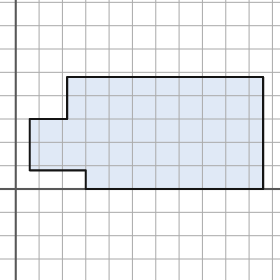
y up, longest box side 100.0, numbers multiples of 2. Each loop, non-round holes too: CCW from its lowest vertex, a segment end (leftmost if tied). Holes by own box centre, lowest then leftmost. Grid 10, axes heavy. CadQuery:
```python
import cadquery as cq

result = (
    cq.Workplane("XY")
    .moveTo(30.0, 0.0)
    .lineTo(106.0, 0.0)
    .lineTo(106.0, 48.0)
    .lineTo(22.0, 48.0)
    .lineTo(22.0, 30.0)
    .lineTo(6.0, 30.0)
    .lineTo(6.0, 8.0)
    .lineTo(30.0, 8.0)
    .close()
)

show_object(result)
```